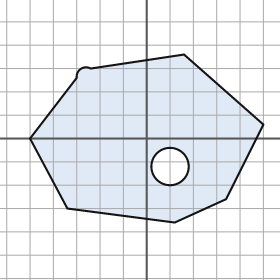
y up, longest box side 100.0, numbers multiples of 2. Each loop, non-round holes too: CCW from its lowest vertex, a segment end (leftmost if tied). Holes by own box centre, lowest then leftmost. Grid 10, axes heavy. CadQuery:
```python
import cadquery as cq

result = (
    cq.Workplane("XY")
    .moveTo(12.0, -36.0)
    .lineTo(34.0, -26.0)
    .lineTo(50.0, 6.0)
    .lineTo(16.0, 36.0)
    .lineTo(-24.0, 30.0)
    .threePointArc((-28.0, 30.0), (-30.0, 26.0))
    .lineTo(-50.0, 0.0)
    .lineTo(-34.0, -30.0)
    .close()
    .moveTo(10.0, -12.0)
    .circle(8.0)
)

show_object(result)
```